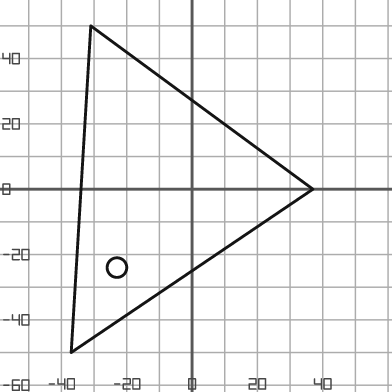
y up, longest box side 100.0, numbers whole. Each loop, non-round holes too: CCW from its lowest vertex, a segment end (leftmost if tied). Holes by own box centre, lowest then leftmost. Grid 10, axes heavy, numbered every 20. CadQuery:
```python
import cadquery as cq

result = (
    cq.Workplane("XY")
    .moveTo(-37.0, -50.0)
    .lineTo(37.0, 0.0)
    .lineTo(-31.0, 50.0)
    .close()
    .moveTo(-23.0, -24.0)
    .circle(3.0)
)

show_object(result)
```